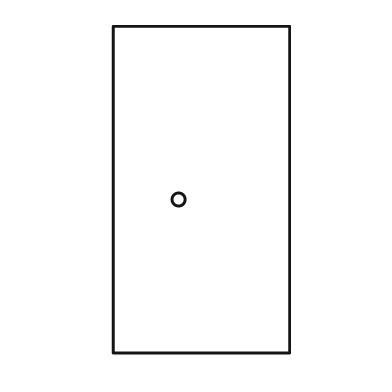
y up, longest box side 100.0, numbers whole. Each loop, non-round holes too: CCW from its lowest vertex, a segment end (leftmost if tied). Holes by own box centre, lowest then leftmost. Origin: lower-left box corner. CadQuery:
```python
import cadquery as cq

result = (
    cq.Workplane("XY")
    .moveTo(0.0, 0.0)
    .lineTo(54.0, 0.0)
    .lineTo(54.0, 100.0)
    .lineTo(0.0, 100.0)
    .close()
    .moveTo(20.0, 47.0)
    .circle(2.0)
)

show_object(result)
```